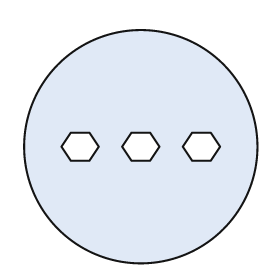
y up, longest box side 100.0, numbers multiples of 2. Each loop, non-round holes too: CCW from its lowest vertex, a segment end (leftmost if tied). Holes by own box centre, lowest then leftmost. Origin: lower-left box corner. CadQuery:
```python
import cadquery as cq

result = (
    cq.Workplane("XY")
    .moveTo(50.0, 50.0)
    .circle(50.0)
    .moveTo(20.0, 44.0)
    .lineTo(28.0, 44.0)
    .lineTo(32.0, 50.0)
    .lineTo(28.0, 56.0)
    .lineTo(20.0, 56.0)
    .lineTo(16.0, 50.0)
    .close()
    .moveTo(46.0, 44.0)
    .lineTo(54.0, 44.0)
    .lineTo(58.0, 50.0)
    .lineTo(54.0, 56.0)
    .lineTo(46.0, 56.0)
    .lineTo(42.0, 50.0)
    .close()
    .moveTo(72.0, 44.0)
    .lineTo(80.0, 44.0)
    .lineTo(84.0, 50.0)
    .lineTo(80.0, 56.0)
    .lineTo(72.0, 56.0)
    .lineTo(68.0, 50.0)
    .close()
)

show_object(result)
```